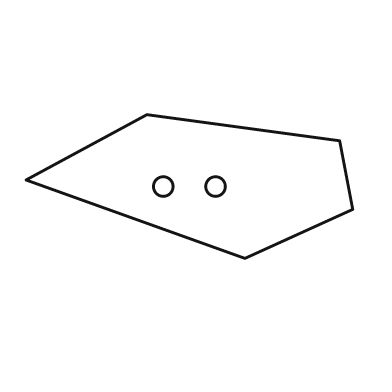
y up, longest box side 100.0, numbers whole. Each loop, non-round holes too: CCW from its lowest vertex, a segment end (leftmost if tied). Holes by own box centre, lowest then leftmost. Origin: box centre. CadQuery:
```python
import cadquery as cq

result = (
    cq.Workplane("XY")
    .moveTo(17.0, -22.0)
    .lineTo(50.0, -7.0)
    .lineTo(46.0, 14.0)
    .lineTo(-13.0, 22.0)
    .lineTo(-50.0, 2.0)
    .close()
    .moveTo(-8.0, 0.0)
    .circle(3.0)
    .moveTo(8.0, 0.0)
    .circle(3.0)
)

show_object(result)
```